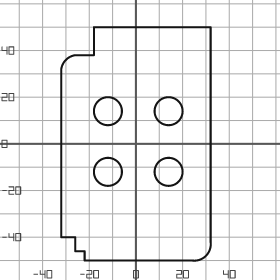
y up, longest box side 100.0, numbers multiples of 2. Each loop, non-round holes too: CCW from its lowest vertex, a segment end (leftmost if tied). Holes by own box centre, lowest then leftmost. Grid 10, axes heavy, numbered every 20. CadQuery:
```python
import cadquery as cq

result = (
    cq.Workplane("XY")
    .moveTo(-22.0, -50.0)
    .lineTo(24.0, -50.0)
    .threePointArc((30.0, -48.0), (32.0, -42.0))
    .lineTo(32.0, 50.0)
    .lineTo(-18.0, 50.0)
    .lineTo(-18.0, 38.0)
    .lineTo(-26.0, 38.0)
    .threePointArc((-30.0, 36.0), (-32.0, 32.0))
    .lineTo(-32.0, -40.0)
    .lineTo(-26.0, -40.0)
    .lineTo(-26.0, -46.0)
    .lineTo(-22.0, -46.0)
    .close()
    .moveTo(-12.0, -12.0)
    .circle(6.0)
    .moveTo(14.0, -12.0)
    .circle(6.0)
    .moveTo(-12.0, 14.0)
    .circle(6.0)
    .moveTo(14.0, 14.0)
    .circle(6.0)
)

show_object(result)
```